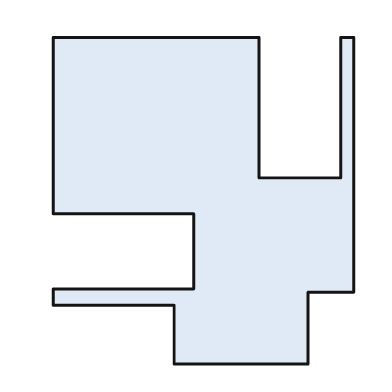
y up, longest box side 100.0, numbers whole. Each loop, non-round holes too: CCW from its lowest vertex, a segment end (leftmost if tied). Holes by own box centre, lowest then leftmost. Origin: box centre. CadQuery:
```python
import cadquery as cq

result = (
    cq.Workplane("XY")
    .moveTo(-9.0, -50.0)
    .lineTo(32.0, -50.0)
    .lineTo(32.0, -28.0)
    .lineTo(46.0, -28.0)
    .lineTo(46.0, 50.0)
    .lineTo(42.0, 50.0)
    .lineTo(42.0, 7.0)
    .lineTo(17.0, 7.0)
    .lineTo(17.0, 50.0)
    .lineTo(-46.0, 50.0)
    .lineTo(-46.0, -4.0)
    .lineTo(-3.0, -4.0)
    .lineTo(-3.0, -27.0)
    .lineTo(-46.0, -27.0)
    .lineTo(-46.0, -32.0)
    .lineTo(-9.0, -32.0)
    .close()
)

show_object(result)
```